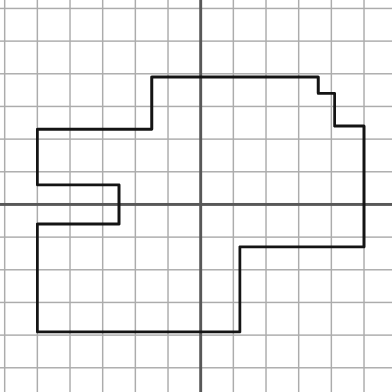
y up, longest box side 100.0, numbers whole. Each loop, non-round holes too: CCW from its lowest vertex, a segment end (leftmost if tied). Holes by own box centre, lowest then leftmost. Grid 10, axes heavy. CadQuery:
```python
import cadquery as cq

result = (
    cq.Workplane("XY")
    .moveTo(-50.0, -39.0)
    .lineTo(12.0, -39.0)
    .lineTo(12.0, -13.0)
    .lineTo(50.0, -13.0)
    .lineTo(50.0, 24.0)
    .lineTo(41.0, 24.0)
    .lineTo(41.0, 34.0)
    .lineTo(36.0, 34.0)
    .lineTo(36.0, 39.0)
    .lineTo(-15.0, 39.0)
    .lineTo(-15.0, 23.0)
    .lineTo(-50.0, 23.0)
    .lineTo(-50.0, 6.0)
    .lineTo(-25.0, 6.0)
    .lineTo(-25.0, -6.0)
    .lineTo(-50.0, -6.0)
    .close()
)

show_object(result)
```